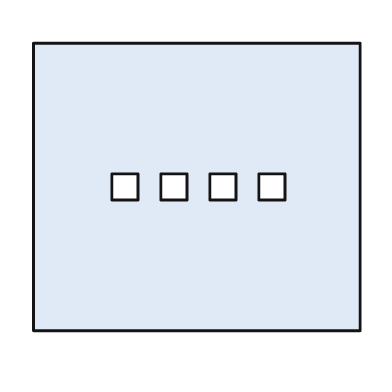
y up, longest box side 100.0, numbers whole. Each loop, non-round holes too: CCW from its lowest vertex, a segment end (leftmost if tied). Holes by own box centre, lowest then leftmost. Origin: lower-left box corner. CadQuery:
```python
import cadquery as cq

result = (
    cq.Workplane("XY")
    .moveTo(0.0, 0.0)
    .lineTo(100.0, 0.0)
    .lineTo(100.0, 88.0)
    .lineTo(0.0, 88.0)
    .close()
    .moveTo(24.0, 40.0)
    .lineTo(32.0, 40.0)
    .lineTo(32.0, 48.0)
    .lineTo(24.0, 48.0)
    .close()
    .moveTo(39.0, 40.0)
    .lineTo(47.0, 40.0)
    .lineTo(47.0, 48.0)
    .lineTo(39.0, 48.0)
    .close()
    .moveTo(54.0, 40.0)
    .lineTo(62.0, 40.0)
    .lineTo(62.0, 48.0)
    .lineTo(54.0, 48.0)
    .close()
    .moveTo(69.0, 40.0)
    .lineTo(77.0, 40.0)
    .lineTo(77.0, 48.0)
    .lineTo(69.0, 48.0)
    .close()
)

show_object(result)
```